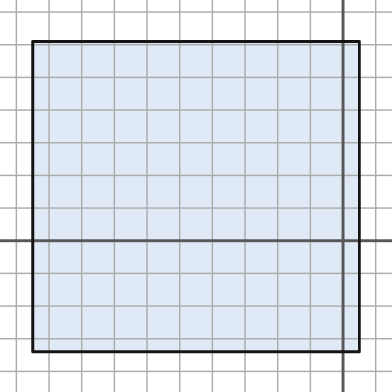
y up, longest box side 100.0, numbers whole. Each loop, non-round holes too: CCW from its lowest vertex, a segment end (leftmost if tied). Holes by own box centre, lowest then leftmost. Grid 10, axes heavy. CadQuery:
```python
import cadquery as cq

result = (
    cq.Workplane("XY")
    .moveTo(-95.0, -34.0)
    .lineTo(5.0, -34.0)
    .lineTo(5.0, 61.0)
    .lineTo(-95.0, 61.0)
    .close()
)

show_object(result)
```